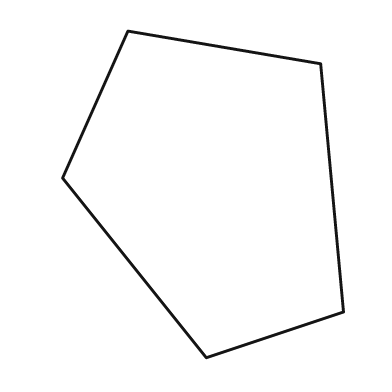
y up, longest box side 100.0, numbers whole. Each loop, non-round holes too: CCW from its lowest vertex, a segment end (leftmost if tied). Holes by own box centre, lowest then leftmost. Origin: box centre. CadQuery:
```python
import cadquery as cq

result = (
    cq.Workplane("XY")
    .moveTo(1.0, -50.0)
    .lineTo(43.0, -36.0)
    .lineTo(36.0, 40.0)
    .lineTo(-23.0, 50.0)
    .lineTo(-43.0, 5.0)
    .close()
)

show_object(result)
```